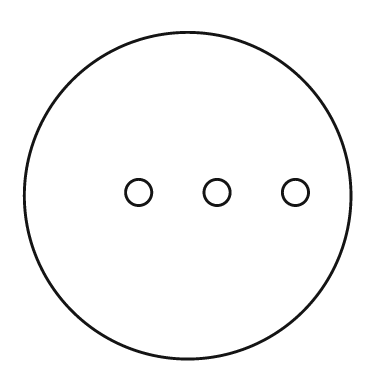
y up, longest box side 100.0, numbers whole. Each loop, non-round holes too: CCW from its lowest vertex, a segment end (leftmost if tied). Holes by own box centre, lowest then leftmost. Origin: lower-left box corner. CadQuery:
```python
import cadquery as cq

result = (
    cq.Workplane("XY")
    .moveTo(50.0, 50.0)
    .circle(50.0)
    .moveTo(35.0, 51.0)
    .circle(4.0)
    .moveTo(59.0, 51.0)
    .circle(4.0)
    .moveTo(83.0, 51.0)
    .circle(4.0)
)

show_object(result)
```